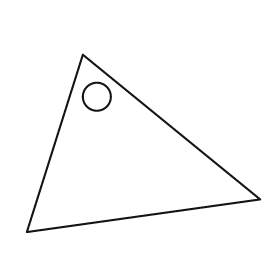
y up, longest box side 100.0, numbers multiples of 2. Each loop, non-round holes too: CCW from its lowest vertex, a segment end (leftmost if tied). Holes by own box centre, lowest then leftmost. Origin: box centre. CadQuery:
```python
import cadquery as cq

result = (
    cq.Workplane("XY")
    .moveTo(-50.0, -38.0)
    .lineTo(50.0, -24.0)
    .lineTo(-26.0, 38.0)
    .close()
    .moveTo(-20.0, 20.0)
    .circle(6.0)
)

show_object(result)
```